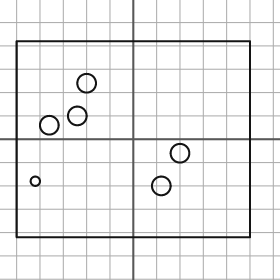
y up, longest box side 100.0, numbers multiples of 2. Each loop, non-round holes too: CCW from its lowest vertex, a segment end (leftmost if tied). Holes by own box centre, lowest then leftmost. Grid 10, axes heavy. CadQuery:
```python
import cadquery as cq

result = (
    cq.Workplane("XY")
    .moveTo(-50.0, -42.0)
    .lineTo(50.0, -42.0)
    .lineTo(50.0, 42.0)
    .lineTo(-50.0, 42.0)
    .close()
    .moveTo(12.0, -20.0)
    .circle(4.0)
    .moveTo(-42.0, -18.0)
    .circle(2.0)
    .moveTo(20.0, -6.0)
    .circle(4.0)
    .moveTo(-36.0, 6.0)
    .circle(4.0)
    .moveTo(-24.0, 10.0)
    .circle(4.0)
    .moveTo(-20.0, 24.0)
    .circle(4.0)
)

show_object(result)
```